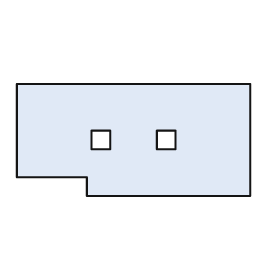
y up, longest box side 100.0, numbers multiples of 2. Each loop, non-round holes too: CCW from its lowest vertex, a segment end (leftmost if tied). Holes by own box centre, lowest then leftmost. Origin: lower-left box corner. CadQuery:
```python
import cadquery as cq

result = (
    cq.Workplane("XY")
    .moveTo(30.0, 0.0)
    .lineTo(100.0, 0.0)
    .lineTo(100.0, 48.0)
    .lineTo(0.0, 48.0)
    .lineTo(0.0, 8.0)
    .lineTo(30.0, 8.0)
    .close()
    .moveTo(32.0, 20.0)
    .lineTo(40.0, 20.0)
    .lineTo(40.0, 28.0)
    .lineTo(32.0, 28.0)
    .close()
    .moveTo(60.0, 20.0)
    .lineTo(68.0, 20.0)
    .lineTo(68.0, 28.0)
    .lineTo(60.0, 28.0)
    .close()
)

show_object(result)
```